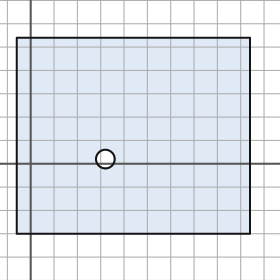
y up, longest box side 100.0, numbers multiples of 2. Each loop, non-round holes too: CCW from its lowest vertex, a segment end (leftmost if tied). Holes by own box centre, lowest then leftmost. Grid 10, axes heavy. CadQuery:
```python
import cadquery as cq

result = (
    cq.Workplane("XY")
    .moveTo(-6.0, -30.0)
    .lineTo(94.0, -30.0)
    .lineTo(94.0, 54.0)
    .lineTo(-6.0, 54.0)
    .close()
    .moveTo(32.0, 2.0)
    .circle(4.0)
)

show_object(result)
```